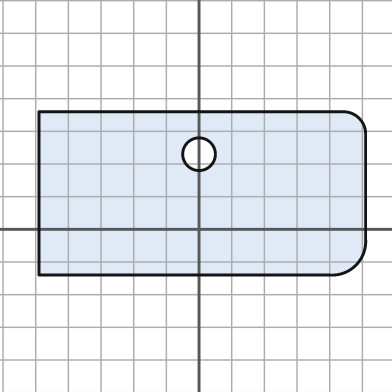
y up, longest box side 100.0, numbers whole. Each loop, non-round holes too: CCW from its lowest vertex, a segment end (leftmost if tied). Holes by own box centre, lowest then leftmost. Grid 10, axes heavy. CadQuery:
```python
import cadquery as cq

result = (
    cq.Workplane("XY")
    .moveTo(-49.0, -14.0)
    .lineTo(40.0, -14.0)
    .threePointArc((48.0, -11.0), (51.0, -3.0))
    .lineTo(51.0, 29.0)
    .threePointArc((49.0, 34.0), (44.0, 36.0))
    .lineTo(-49.0, 36.0)
    .close()
    .moveTo(0.0, 23.0)
    .circle(5.0)
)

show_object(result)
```